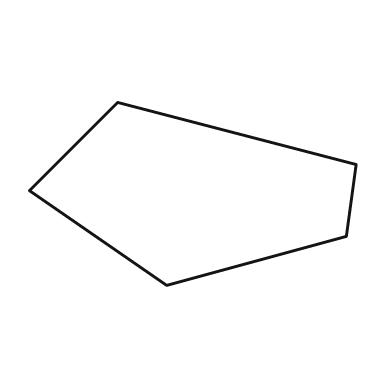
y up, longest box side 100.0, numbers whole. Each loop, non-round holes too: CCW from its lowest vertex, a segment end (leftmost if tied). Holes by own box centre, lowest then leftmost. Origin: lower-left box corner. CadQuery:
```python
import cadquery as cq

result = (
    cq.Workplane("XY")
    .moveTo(42.0, 0.0)
    .lineTo(97.0, 15.0)
    .lineTo(100.0, 37.0)
    .lineTo(27.0, 56.0)
    .lineTo(0.0, 29.0)
    .close()
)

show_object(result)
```